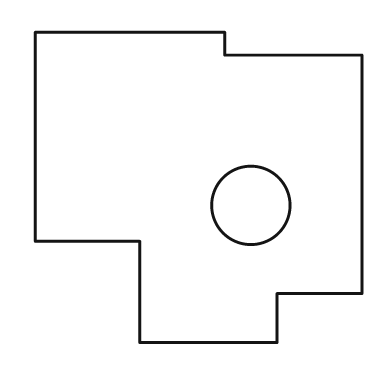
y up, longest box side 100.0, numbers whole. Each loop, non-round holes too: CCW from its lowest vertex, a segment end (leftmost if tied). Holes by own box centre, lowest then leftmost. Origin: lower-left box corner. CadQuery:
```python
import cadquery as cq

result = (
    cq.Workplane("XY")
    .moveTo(32.0, 0.0)
    .lineTo(74.0, 0.0)
    .lineTo(74.0, 15.0)
    .lineTo(100.0, 15.0)
    .lineTo(100.0, 88.0)
    .lineTo(58.0, 88.0)
    .lineTo(58.0, 95.0)
    .lineTo(0.0, 95.0)
    .lineTo(0.0, 31.0)
    .lineTo(32.0, 31.0)
    .close()
    .moveTo(66.0, 42.0)
    .circle(12.0)
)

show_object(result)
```